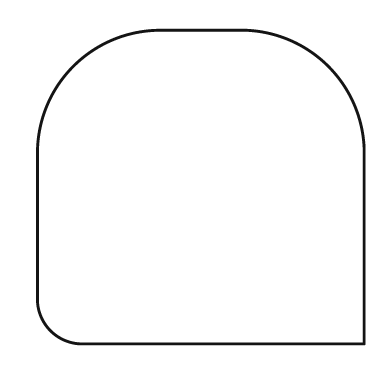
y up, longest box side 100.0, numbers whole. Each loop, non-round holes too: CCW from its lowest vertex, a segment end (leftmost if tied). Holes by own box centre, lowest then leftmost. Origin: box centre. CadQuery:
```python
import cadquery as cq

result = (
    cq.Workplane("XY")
    .moveTo(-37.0, -48.0)
    .lineTo(50.0, -48.0)
    .lineTo(50.0, 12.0)
    .threePointArc((39.0, 37.0), (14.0, 48.0))
    .lineTo(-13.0, 48.0)
    .threePointArc((-39.0, 37.0), (-50.0, 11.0))
    .lineTo(-50.0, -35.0)
    .threePointArc((-46.0, -44.0), (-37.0, -48.0))
    .close()
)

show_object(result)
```